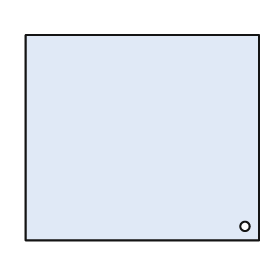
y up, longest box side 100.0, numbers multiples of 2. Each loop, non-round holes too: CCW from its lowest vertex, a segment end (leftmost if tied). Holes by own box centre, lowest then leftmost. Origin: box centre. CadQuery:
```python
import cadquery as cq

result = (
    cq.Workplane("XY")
    .moveTo(-50.0, -44.0)
    .lineTo(50.0, -44.0)
    .lineTo(50.0, 44.0)
    .lineTo(-50.0, 44.0)
    .close()
    .moveTo(44.0, -38.0)
    .circle(2.0)
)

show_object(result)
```